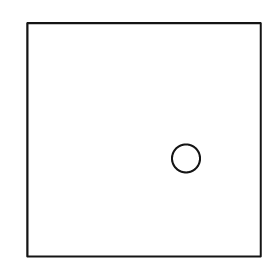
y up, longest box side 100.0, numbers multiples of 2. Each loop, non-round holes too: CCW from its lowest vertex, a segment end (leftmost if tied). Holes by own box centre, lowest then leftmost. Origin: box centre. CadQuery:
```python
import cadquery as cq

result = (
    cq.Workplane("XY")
    .moveTo(-50.0, -50.0)
    .lineTo(50.0, -50.0)
    .lineTo(50.0, 50.0)
    .lineTo(-50.0, 50.0)
    .close()
    .moveTo(18.0, -8.0)
    .circle(6.0)
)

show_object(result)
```